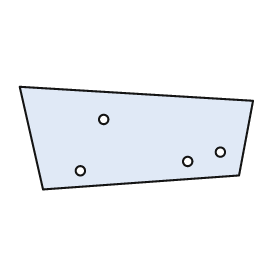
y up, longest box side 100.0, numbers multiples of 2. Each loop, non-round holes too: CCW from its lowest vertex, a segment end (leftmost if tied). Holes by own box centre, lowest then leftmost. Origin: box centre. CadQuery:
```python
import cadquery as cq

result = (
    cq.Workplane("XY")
    .moveTo(-40.0, -22.0)
    .lineTo(44.0, -16.0)
    .lineTo(50.0, 16.0)
    .lineTo(-50.0, 22.0)
    .close()
    .moveTo(-24.0, -14.0)
    .circle(2.0)
    .moveTo(22.0, -10.0)
    .circle(2.0)
    .moveTo(36.0, -6.0)
    .circle(2.0)
    .moveTo(-14.0, 8.0)
    .circle(2.0)
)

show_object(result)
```